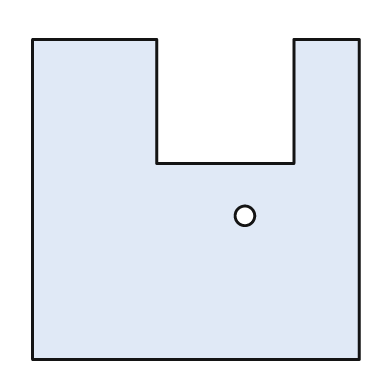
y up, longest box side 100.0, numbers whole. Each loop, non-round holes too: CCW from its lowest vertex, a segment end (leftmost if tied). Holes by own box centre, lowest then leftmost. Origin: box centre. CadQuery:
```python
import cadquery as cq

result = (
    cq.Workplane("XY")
    .moveTo(-50.0, -49.0)
    .lineTo(50.0, -49.0)
    .lineTo(50.0, 49.0)
    .lineTo(30.0, 49.0)
    .lineTo(30.0, 11.0)
    .lineTo(-12.0, 11.0)
    .lineTo(-12.0, 49.0)
    .lineTo(-50.0, 49.0)
    .close()
    .moveTo(15.0, -5.0)
    .circle(3.0)
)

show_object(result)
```